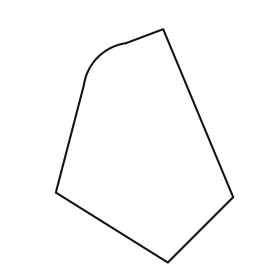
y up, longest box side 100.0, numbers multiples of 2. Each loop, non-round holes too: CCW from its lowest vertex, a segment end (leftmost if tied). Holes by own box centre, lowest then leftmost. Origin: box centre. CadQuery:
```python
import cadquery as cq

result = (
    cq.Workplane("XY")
    .moveTo(10.0, -50.0)
    .lineTo(38.0, -22.0)
    .lineTo(8.0, 50.0)
    .lineTo(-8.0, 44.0)
    .threePointArc((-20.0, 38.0), (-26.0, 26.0))
    .lineTo(-38.0, -20.0)
    .close()
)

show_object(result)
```